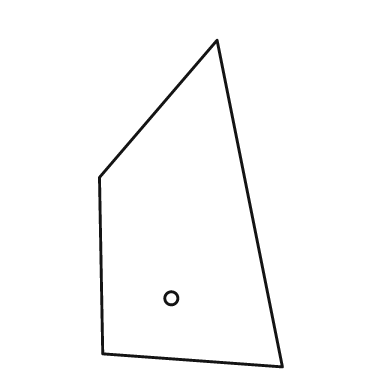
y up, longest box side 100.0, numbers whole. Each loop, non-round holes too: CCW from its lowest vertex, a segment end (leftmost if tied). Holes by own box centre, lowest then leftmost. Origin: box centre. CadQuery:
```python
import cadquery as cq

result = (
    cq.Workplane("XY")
    .moveTo(28.0, -50.0)
    .lineTo(8.0, 50.0)
    .lineTo(-28.0, 8.0)
    .lineTo(-27.0, -46.0)
    .close()
    .moveTo(-6.0, -29.0)
    .circle(2.0)
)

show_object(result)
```